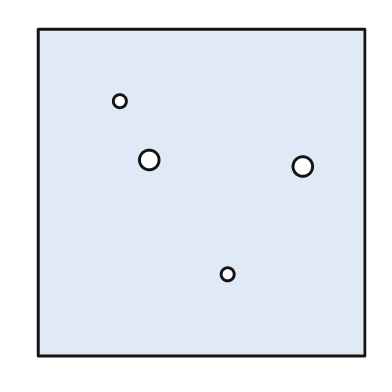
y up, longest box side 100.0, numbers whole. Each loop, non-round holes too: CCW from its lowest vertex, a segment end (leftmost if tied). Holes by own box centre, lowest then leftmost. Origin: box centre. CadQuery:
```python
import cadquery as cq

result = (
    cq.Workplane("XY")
    .moveTo(-50.0, -50.0)
    .lineTo(50.0, -50.0)
    .lineTo(50.0, 50.0)
    .lineTo(-50.0, 50.0)
    .close()
    .moveTo(8.0, -25.0)
    .circle(2.0)
    .moveTo(31.0, 8.0)
    .circle(3.0)
    .moveTo(-16.0, 10.0)
    .circle(3.0)
    .moveTo(-25.0, 28.0)
    .circle(2.0)
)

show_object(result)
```